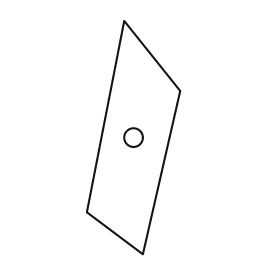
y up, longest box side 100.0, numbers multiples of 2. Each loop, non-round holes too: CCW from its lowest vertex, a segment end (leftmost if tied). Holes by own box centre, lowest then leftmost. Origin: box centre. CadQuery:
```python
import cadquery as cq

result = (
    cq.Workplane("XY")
    .moveTo(4.0, -50.0)
    .lineTo(20.0, 20.0)
    .lineTo(-4.0, 50.0)
    .lineTo(-20.0, -32.0)
    .close()
    .moveTo(0.0, 0.0)
    .circle(4.0)
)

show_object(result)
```